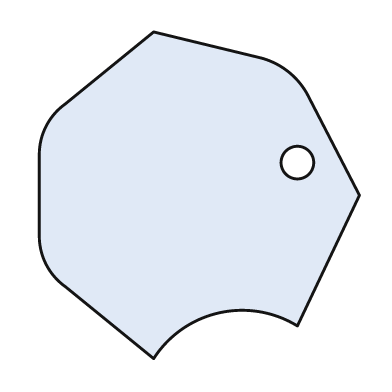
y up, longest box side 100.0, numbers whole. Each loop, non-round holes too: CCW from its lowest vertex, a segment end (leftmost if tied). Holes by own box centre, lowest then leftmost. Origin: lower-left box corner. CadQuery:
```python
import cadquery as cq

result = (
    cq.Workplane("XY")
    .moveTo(35.0, 0.0)
    .threePointArc((55.0, 14.0), (79.0, 10.0))
    .lineTo(98.0, 50.0)
    .lineTo(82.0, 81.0)
    .threePointArc((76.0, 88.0), (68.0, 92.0))
    .lineTo(35.0, 100.0)
    .lineTo(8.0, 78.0)
    .threePointArc((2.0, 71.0), (0.0, 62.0))
    .lineTo(0.0, 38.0)
    .threePointArc((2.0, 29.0), (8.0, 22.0))
    .close()
    .moveTo(79.0, 60.0)
    .circle(5.0)
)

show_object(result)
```